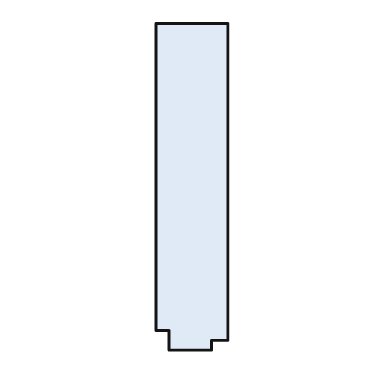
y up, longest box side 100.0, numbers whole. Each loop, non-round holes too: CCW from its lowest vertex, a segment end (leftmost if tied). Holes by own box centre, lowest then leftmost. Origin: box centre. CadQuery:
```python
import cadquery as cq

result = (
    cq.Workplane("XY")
    .moveTo(-7.0, -50.0)
    .lineTo(6.0, -50.0)
    .lineTo(6.0, -47.0)
    .lineTo(11.0, -47.0)
    .lineTo(11.0, 50.0)
    .lineTo(-11.0, 50.0)
    .lineTo(-11.0, -44.0)
    .lineTo(-7.0, -44.0)
    .close()
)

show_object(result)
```